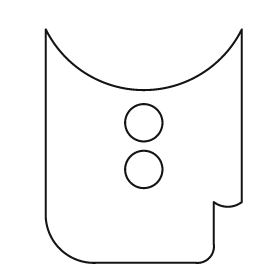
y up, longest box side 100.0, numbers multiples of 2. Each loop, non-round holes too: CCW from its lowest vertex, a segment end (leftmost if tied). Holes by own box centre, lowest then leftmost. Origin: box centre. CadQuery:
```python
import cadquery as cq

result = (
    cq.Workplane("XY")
    .moveTo(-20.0, -50.0)
    .lineTo(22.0, -50.0)
    .threePointArc((28.0, -48.0), (30.0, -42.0))
    .lineTo(30.0, -24.0)
    .threePointArc((36.0, -26.0), (42.0, -24.0))
    .lineTo(42.0, 50.0)
    .threePointArc((0.0, 24.0), (-42.0, 50.0))
    .lineTo(-42.0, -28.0)
    .threePointArc((-36.0, -44.0), (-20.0, -50.0))
    .close()
    .moveTo(0.0, -10.0)
    .circle(8.0)
    .moveTo(0.0, 10.0)
    .circle(8.0)
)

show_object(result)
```